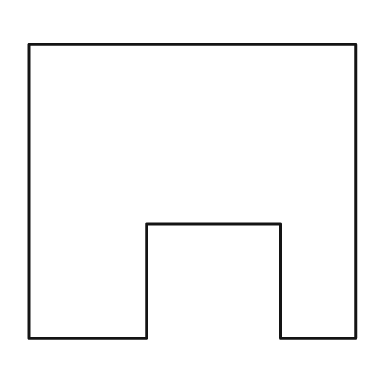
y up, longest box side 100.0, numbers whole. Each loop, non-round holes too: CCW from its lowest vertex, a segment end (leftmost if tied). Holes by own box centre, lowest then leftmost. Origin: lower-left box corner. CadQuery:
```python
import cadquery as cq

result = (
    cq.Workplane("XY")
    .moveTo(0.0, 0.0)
    .lineTo(36.0, 0.0)
    .lineTo(36.0, 35.0)
    .lineTo(77.0, 35.0)
    .lineTo(77.0, 0.0)
    .lineTo(100.0, 0.0)
    .lineTo(100.0, 90.0)
    .lineTo(0.0, 90.0)
    .close()
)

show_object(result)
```